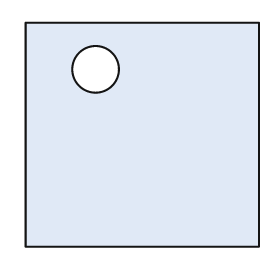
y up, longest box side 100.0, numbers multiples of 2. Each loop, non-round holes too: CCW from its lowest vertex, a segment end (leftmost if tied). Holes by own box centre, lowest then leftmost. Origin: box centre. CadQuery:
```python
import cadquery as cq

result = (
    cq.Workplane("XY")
    .moveTo(-50.0, -48.0)
    .lineTo(50.0, -48.0)
    .lineTo(50.0, 48.0)
    .lineTo(-50.0, 48.0)
    .close()
    .moveTo(-20.0, 28.0)
    .circle(10.0)
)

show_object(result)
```